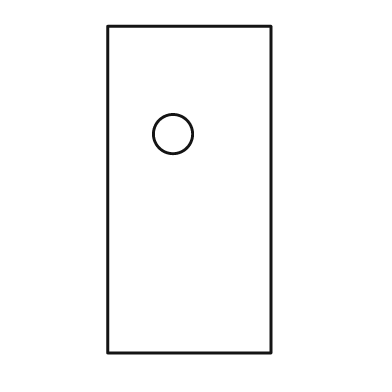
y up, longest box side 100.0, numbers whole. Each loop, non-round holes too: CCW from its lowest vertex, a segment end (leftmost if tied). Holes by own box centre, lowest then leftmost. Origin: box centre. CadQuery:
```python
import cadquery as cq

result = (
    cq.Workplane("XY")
    .moveTo(-25.0, -50.0)
    .lineTo(25.0, -50.0)
    .lineTo(25.0, 50.0)
    .lineTo(-25.0, 50.0)
    .close()
    .moveTo(-5.0, 17.0)
    .circle(6.0)
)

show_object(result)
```